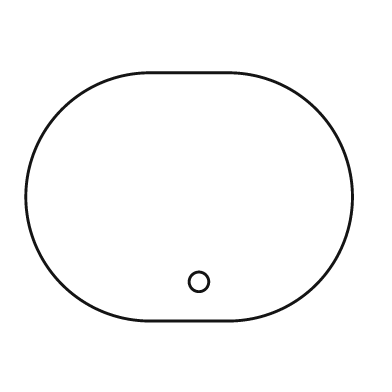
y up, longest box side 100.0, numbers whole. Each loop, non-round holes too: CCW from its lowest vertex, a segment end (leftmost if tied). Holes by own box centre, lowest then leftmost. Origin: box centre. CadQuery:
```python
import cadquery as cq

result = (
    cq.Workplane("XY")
    .moveTo(-12.0, -38.0)
    .lineTo(12.0, -38.0)
    .threePointArc((50.0, 0.0), (12.0, 38.0))
    .lineTo(-12.0, 38.0)
    .threePointArc((-50.0, 0.0), (-12.0, -38.0))
    .close()
    .moveTo(3.0, -26.0)
    .circle(3.0)
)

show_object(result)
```